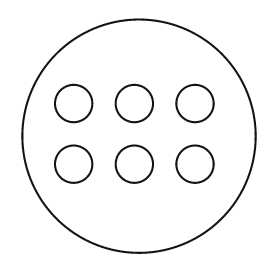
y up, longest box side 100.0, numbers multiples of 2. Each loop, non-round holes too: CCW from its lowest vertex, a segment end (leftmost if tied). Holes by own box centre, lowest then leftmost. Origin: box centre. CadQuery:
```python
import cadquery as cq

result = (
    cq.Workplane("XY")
    .moveTo(0.0, 0.0)
    .circle(50.0)
    .moveTo(-28.0, -12.0)
    .circle(8.0)
    .moveTo(-2.0, -12.0)
    .circle(8.0)
    .moveTo(24.0, -12.0)
    .circle(8.0)
    .moveTo(-28.0, 14.0)
    .circle(8.0)
    .moveTo(-2.0, 14.0)
    .circle(8.0)
    .moveTo(24.0, 14.0)
    .circle(8.0)
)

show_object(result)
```